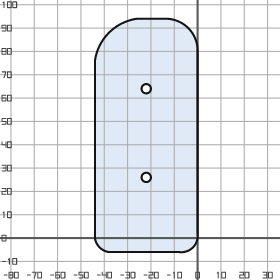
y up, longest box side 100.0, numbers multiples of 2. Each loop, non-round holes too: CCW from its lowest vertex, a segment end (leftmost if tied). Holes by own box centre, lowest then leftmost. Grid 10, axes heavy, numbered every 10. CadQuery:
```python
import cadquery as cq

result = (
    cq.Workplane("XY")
    .moveTo(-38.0, -6.0)
    .lineTo(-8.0, -6.0)
    .threePointArc((-2.0, -4.0), (0.0, 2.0))
    .lineTo(0.0, 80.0)
    .threePointArc((-4.0, 90.0), (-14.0, 94.0))
    .lineTo(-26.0, 94.0)
    .threePointArc((-38.0, 88.0), (-44.0, 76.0))
    .lineTo(-44.0, 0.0)
    .threePointArc((-42.0, -4.0), (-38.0, -6.0))
    .close()
    .moveTo(-22.0, 26.0)
    .circle(2.0)
    .moveTo(-22.0, 64.0)
    .circle(2.0)
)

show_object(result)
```